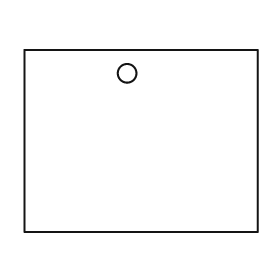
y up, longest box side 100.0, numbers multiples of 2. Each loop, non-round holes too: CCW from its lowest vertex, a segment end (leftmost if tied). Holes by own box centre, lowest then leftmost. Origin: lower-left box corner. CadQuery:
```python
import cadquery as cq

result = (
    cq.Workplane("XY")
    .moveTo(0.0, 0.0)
    .lineTo(100.0, 0.0)
    .lineTo(100.0, 78.0)
    .lineTo(0.0, 78.0)
    .close()
    .moveTo(44.0, 68.0)
    .circle(4.0)
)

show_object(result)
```